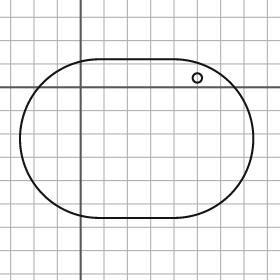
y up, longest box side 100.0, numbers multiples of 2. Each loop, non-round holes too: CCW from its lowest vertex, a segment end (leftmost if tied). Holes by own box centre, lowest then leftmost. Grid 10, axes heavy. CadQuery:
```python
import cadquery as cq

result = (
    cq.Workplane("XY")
    .moveTo(8.0, -56.0)
    .lineTo(40.0, -56.0)
    .threePointArc((74.0, -22.0), (40.0, 12.0))
    .lineTo(8.0, 12.0)
    .threePointArc((-26.0, -22.0), (8.0, -56.0))
    .close()
    .moveTo(50.0, 4.0)
    .circle(2.0)
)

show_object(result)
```